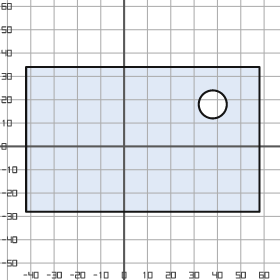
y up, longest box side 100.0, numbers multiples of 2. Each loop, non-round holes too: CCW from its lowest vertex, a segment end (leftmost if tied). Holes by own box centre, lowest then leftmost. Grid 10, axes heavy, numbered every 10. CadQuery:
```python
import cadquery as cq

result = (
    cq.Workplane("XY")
    .moveTo(-42.0, -28.0)
    .lineTo(58.0, -28.0)
    .lineTo(58.0, 34.0)
    .lineTo(-42.0, 34.0)
    .close()
    .moveTo(38.0, 18.0)
    .circle(6.0)
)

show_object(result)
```